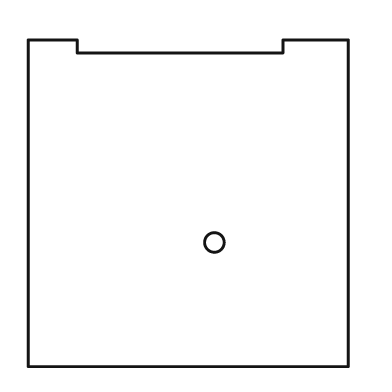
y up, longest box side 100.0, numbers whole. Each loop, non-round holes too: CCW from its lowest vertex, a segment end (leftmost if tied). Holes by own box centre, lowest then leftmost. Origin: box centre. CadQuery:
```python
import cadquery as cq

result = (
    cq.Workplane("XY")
    .moveTo(-49.0, -50.0)
    .lineTo(49.0, -50.0)
    .lineTo(49.0, 50.0)
    .lineTo(29.0, 50.0)
    .lineTo(29.0, 46.0)
    .lineTo(-34.0, 46.0)
    .lineTo(-34.0, 50.0)
    .lineTo(-49.0, 50.0)
    .close()
    .moveTo(8.0, -12.0)
    .circle(3.0)
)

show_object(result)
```